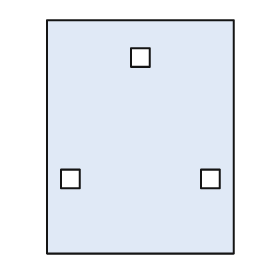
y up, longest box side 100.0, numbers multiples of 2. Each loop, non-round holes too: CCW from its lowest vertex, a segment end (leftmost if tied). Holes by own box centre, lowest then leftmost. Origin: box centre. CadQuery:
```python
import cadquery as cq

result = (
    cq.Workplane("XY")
    .moveTo(-40.0, -50.0)
    .lineTo(40.0, -50.0)
    .lineTo(40.0, 50.0)
    .lineTo(-40.0, 50.0)
    .close()
    .moveTo(-34.0, -22.0)
    .lineTo(-26.0, -22.0)
    .lineTo(-26.0, -14.0)
    .lineTo(-34.0, -14.0)
    .close()
    .moveTo(26.0, -22.0)
    .lineTo(34.0, -22.0)
    .lineTo(34.0, -14.0)
    .lineTo(26.0, -14.0)
    .close()
    .moveTo(-4.0, 30.0)
    .lineTo(4.0, 30.0)
    .lineTo(4.0, 38.0)
    .lineTo(-4.0, 38.0)
    .close()
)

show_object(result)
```